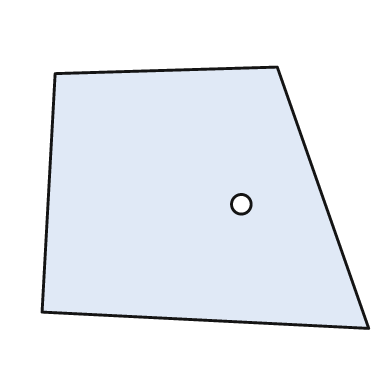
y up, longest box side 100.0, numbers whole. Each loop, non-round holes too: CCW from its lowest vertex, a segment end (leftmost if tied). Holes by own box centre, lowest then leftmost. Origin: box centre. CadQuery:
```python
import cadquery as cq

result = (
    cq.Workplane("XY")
    .moveTo(50.0, -40.0)
    .lineTo(22.0, 40.0)
    .lineTo(-46.0, 38.0)
    .lineTo(-50.0, -35.0)
    .close()
    .moveTo(11.0, -2.0)
    .circle(3.0)
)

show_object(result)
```